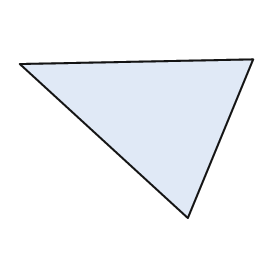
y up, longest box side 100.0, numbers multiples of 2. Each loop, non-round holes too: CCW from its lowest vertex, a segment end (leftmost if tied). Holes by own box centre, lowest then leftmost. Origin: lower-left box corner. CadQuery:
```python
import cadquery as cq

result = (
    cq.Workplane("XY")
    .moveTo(72.0, 0.0)
    .lineTo(100.0, 68.0)
    .lineTo(0.0, 66.0)
    .close()
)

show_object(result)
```